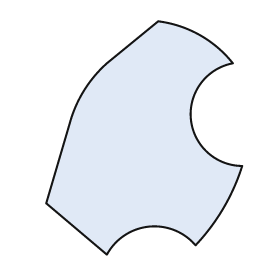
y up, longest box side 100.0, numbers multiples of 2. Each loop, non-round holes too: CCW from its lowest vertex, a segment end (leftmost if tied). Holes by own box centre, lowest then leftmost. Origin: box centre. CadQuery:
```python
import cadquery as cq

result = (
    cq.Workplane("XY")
    .moveTo(-16.0, -50.0)
    .threePointArc((2.0, -38.0), (22.0, -46.0))
    .threePointArc((34.0, -30.0), (42.0, -12.0))
    .threePointArc((20.0, 8.0), (38.0, 32.0))
    .threePointArc((24.0, 44.0), (6.0, 50.0))
    .lineTo(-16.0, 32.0)
    .threePointArc((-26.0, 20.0), (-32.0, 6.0))
    .lineTo(-42.0, -28.0)
    .close()
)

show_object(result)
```